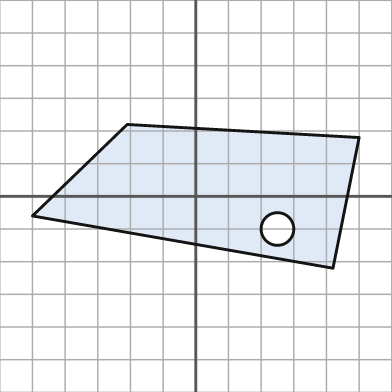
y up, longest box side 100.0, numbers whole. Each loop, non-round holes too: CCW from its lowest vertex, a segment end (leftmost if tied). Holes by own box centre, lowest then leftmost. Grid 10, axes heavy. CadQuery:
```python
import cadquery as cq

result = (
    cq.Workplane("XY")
    .moveTo(42.0, -22.0)
    .lineTo(50.0, 18.0)
    .lineTo(-21.0, 22.0)
    .lineTo(-50.0, -6.0)
    .close()
    .moveTo(25.0, -10.0)
    .circle(5.0)
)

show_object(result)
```